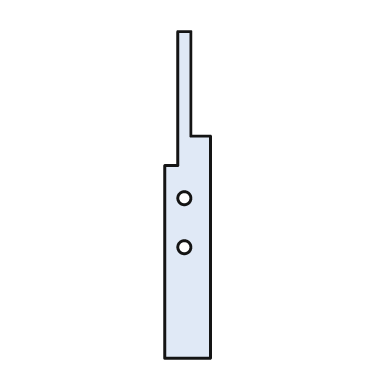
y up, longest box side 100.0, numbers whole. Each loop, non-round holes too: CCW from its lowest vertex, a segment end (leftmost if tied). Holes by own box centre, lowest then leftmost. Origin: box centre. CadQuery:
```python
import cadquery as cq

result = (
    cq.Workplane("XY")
    .moveTo(-7.0, -50.0)
    .lineTo(7.0, -50.0)
    .lineTo(7.0, 18.0)
    .lineTo(1.0, 18.0)
    .lineTo(1.0, 50.0)
    .lineTo(-3.0, 50.0)
    .lineTo(-3.0, 9.0)
    .lineTo(-7.0, 9.0)
    .close()
    .moveTo(-1.0, -16.0)
    .circle(2.0)
    .moveTo(-1.0, -1.0)
    .circle(2.0)
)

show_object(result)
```